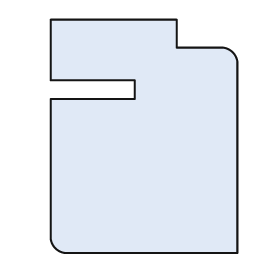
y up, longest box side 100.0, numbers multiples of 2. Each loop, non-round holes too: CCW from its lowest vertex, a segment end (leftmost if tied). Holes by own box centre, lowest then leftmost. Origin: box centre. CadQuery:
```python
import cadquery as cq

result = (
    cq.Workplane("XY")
    .moveTo(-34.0, -50.0)
    .lineTo(40.0, -50.0)
    .lineTo(40.0, 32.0)
    .threePointArc((38.0, 36.0), (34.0, 38.0))
    .lineTo(14.0, 38.0)
    .lineTo(14.0, 50.0)
    .lineTo(-40.0, 50.0)
    .lineTo(-40.0, 24.0)
    .lineTo(-4.0, 24.0)
    .lineTo(-4.0, 16.0)
    .lineTo(-40.0, 16.0)
    .lineTo(-40.0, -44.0)
    .threePointArc((-38.0, -48.0), (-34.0, -50.0))
    .close()
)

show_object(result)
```